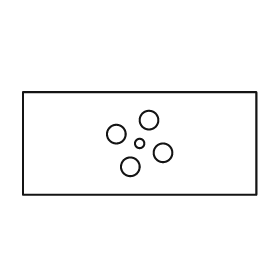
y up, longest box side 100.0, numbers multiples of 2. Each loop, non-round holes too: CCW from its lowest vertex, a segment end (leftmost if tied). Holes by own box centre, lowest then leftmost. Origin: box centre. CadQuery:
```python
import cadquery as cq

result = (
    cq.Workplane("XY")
    .moveTo(-50.0, -22.0)
    .lineTo(50.0, -22.0)
    .lineTo(50.0, 22.0)
    .lineTo(-50.0, 22.0)
    .close()
    .moveTo(-4.0, -10.0)
    .circle(4.0)
    .moveTo(10.0, -4.0)
    .circle(4.0)
    .moveTo(0.0, 0.0)
    .circle(2.0)
    .moveTo(-10.0, 4.0)
    .circle(4.0)
    .moveTo(4.0, 10.0)
    .circle(4.0)
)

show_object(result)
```